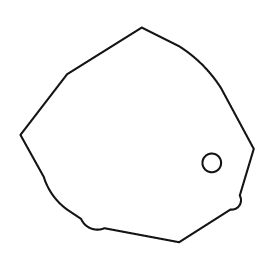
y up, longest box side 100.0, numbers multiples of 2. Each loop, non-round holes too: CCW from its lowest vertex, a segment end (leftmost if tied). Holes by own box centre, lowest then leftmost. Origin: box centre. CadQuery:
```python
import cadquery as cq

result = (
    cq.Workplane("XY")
    .moveTo(18.0, -46.0)
    .lineTo(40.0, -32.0)
    .threePointArc((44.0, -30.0), (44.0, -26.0))
    .lineTo(50.0, -6.0)
    .lineTo(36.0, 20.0)
    .threePointArc((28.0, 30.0), (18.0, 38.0))
    .lineTo(2.0, 46.0)
    .lineTo(-30.0, 26.0)
    .lineTo(-50.0, 0.0)
    .lineTo(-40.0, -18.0)
    .threePointArc((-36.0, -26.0), (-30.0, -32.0))
    .lineTo(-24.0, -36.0)
    .threePointArc((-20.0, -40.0), (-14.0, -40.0))
    .close()
    .moveTo(32.0, -12.0)
    .circle(4.0)
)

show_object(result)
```